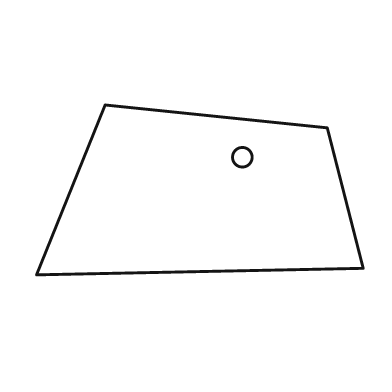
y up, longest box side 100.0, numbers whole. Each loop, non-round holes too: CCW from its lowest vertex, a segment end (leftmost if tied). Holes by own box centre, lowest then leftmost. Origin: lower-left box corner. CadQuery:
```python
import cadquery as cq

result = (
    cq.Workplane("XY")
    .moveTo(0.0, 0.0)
    .lineTo(100.0, 2.0)
    .lineTo(89.0, 45.0)
    .lineTo(21.0, 52.0)
    .close()
    .moveTo(63.0, 36.0)
    .circle(3.0)
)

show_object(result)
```